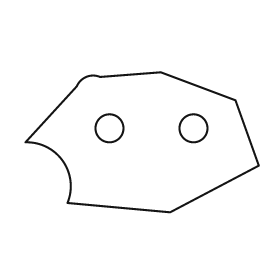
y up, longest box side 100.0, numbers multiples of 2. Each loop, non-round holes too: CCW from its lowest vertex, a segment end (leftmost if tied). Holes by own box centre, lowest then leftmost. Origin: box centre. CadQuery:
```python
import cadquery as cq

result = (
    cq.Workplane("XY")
    .moveTo(12.0, -30.0)
    .lineTo(50.0, -10.0)
    .lineTo(40.0, 18.0)
    .lineTo(8.0, 30.0)
    .lineTo(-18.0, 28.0)
    .threePointArc((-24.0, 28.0), (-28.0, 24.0))
    .lineTo(-50.0, 0.0)
    .threePointArc((-34.0, -8.0), (-32.0, -26.0))
    .close()
    .moveTo(-14.0, 6.0)
    .circle(6.0)
    .moveTo(22.0, 6.0)
    .circle(6.0)
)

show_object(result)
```